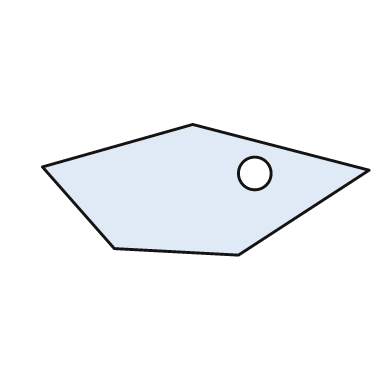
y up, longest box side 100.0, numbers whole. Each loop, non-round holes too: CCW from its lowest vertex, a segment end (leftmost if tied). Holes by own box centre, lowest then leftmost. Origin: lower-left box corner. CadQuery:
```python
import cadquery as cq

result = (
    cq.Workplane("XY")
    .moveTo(60.0, 0.0)
    .lineTo(100.0, 26.0)
    .lineTo(46.0, 40.0)
    .lineTo(0.0, 27.0)
    .lineTo(22.0, 2.0)
    .close()
    .moveTo(65.0, 25.0)
    .circle(5.0)
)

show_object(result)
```